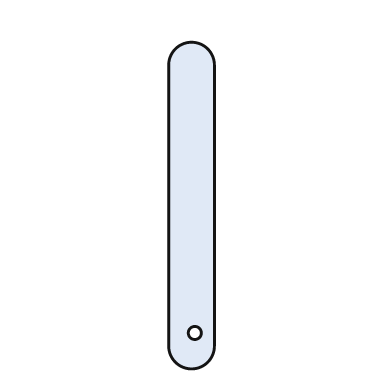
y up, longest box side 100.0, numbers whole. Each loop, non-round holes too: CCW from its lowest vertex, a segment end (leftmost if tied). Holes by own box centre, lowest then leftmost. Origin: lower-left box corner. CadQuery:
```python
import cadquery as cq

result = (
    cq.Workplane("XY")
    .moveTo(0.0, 7.0)
    .threePointArc((7.0, 0.0), (14.0, 7.0))
    .lineTo(14.0, 93.0)
    .threePointArc((7.0, 100.0), (0.0, 93.0))
    .close()
    .moveTo(8.0, 11.0)
    .circle(2.0)
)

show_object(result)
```